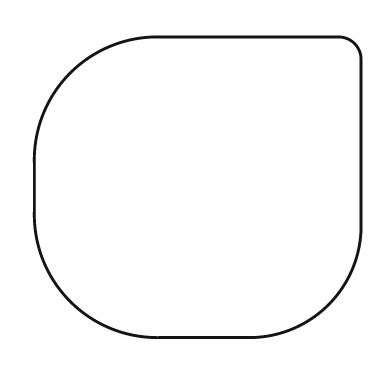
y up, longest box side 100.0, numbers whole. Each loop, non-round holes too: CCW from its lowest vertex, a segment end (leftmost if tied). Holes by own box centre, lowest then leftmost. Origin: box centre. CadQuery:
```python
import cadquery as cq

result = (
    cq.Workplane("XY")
    .moveTo(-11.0, -46.0)
    .lineTo(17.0, -46.0)
    .threePointArc((40.0, -36.0), (50.0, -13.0))
    .lineTo(50.0, 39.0)
    .threePointArc((48.0, 44.0), (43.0, 46.0))
    .lineTo(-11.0, 46.0)
    .threePointArc((-39.0, 35.0), (-50.0, 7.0))
    .lineTo(-50.0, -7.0)
    .threePointArc((-39.0, -35.0), (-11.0, -46.0))
    .close()
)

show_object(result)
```